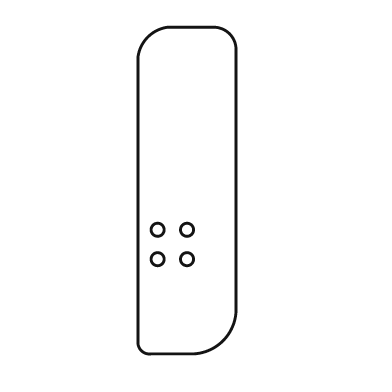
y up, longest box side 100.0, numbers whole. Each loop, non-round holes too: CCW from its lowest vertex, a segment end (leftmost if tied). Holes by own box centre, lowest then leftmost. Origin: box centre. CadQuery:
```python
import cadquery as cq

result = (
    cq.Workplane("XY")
    .moveTo(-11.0, -50.0)
    .lineTo(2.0, -50.0)
    .threePointArc((11.0, -46.0), (15.0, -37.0))
    .lineTo(15.0, 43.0)
    .threePointArc((13.0, 48.0), (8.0, 50.0))
    .lineTo(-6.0, 50.0)
    .threePointArc((-12.0, 47.0), (-15.0, 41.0))
    .lineTo(-15.0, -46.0)
    .threePointArc((-14.0, -49.0), (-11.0, -50.0))
    .close()
    .moveTo(-9.0, -21.0)
    .circle(2.0)
    .moveTo(0.0, -21.0)
    .circle(2.0)
    .moveTo(-9.0, -12.0)
    .circle(2.0)
    .moveTo(0.0, -12.0)
    .circle(2.0)
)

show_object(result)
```